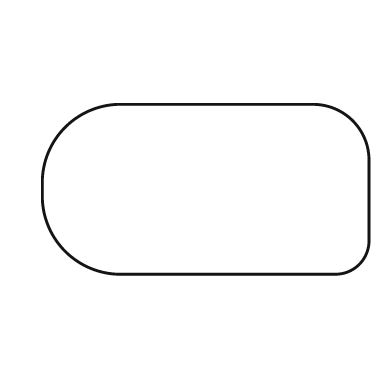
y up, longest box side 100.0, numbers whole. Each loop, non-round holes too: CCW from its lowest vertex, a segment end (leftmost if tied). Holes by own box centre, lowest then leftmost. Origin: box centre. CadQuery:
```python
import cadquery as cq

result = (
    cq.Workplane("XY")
    .moveTo(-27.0, -26.0)
    .lineTo(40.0, -26.0)
    .threePointArc((47.0, -23.0), (50.0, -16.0))
    .lineTo(50.0, 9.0)
    .threePointArc((45.0, 21.0), (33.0, 26.0))
    .lineTo(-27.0, 26.0)
    .threePointArc((-43.0, 19.0), (-50.0, 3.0))
    .lineTo(-50.0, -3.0)
    .threePointArc((-43.0, -19.0), (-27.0, -26.0))
    .close()
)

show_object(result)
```